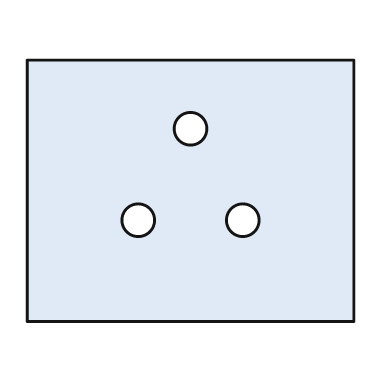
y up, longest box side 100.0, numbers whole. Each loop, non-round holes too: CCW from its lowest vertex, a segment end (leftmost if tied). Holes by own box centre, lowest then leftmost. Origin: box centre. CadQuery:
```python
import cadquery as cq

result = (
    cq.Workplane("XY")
    .moveTo(-50.0, -40.0)
    .lineTo(50.0, -40.0)
    .lineTo(50.0, 40.0)
    .lineTo(-50.0, 40.0)
    .close()
    .moveTo(-16.0, -9.0)
    .circle(5.0)
    .moveTo(16.0, -9.0)
    .circle(5.0)
    .moveTo(0.0, 19.0)
    .circle(5.0)
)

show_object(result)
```